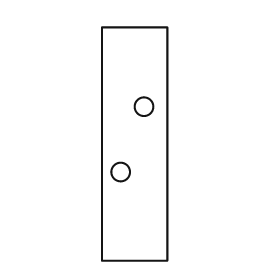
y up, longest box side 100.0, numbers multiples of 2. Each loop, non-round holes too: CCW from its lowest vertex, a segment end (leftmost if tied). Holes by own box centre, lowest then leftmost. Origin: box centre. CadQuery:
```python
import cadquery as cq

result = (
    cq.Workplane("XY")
    .moveTo(-14.0, -50.0)
    .lineTo(14.0, -50.0)
    .lineTo(14.0, 50.0)
    .lineTo(-14.0, 50.0)
    .close()
    .moveTo(-6.0, -12.0)
    .circle(4.0)
    .moveTo(4.0, 16.0)
    .circle(4.0)
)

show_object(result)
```